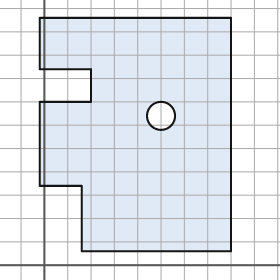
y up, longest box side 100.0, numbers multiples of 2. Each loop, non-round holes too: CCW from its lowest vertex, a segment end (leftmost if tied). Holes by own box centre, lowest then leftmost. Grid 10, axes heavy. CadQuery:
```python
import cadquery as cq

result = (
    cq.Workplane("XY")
    .moveTo(16.0, 6.0)
    .lineTo(80.0, 6.0)
    .lineTo(80.0, 106.0)
    .lineTo(-2.0, 106.0)
    .lineTo(-2.0, 84.0)
    .lineTo(20.0, 84.0)
    .lineTo(20.0, 70.0)
    .lineTo(-2.0, 70.0)
    .lineTo(-2.0, 34.0)
    .lineTo(16.0, 34.0)
    .close()
    .moveTo(50.0, 64.0)
    .circle(6.0)
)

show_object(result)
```